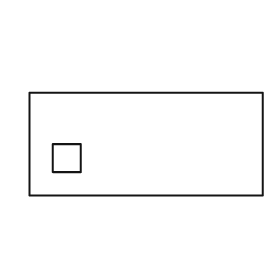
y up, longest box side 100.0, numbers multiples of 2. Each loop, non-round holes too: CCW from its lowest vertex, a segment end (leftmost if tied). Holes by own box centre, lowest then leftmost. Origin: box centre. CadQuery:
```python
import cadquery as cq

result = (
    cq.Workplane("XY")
    .moveTo(-50.0, -22.0)
    .lineTo(50.0, -22.0)
    .lineTo(50.0, 22.0)
    .lineTo(-50.0, 22.0)
    .close()
    .moveTo(-40.0, -12.0)
    .lineTo(-28.0, -12.0)
    .lineTo(-28.0, 0.0)
    .lineTo(-40.0, 0.0)
    .close()
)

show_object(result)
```